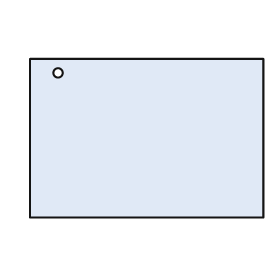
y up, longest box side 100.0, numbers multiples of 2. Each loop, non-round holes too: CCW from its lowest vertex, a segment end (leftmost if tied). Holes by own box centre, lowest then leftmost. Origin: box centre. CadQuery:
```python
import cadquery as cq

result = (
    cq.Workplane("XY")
    .moveTo(-50.0, -34.0)
    .lineTo(50.0, -34.0)
    .lineTo(50.0, 34.0)
    .lineTo(-50.0, 34.0)
    .close()
    .moveTo(-38.0, 28.0)
    .circle(2.0)
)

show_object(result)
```